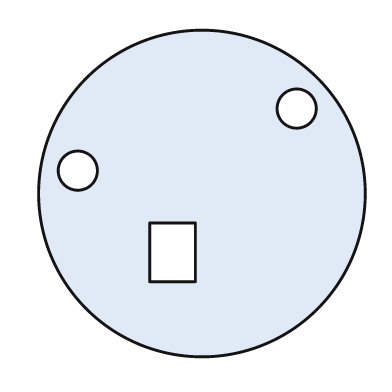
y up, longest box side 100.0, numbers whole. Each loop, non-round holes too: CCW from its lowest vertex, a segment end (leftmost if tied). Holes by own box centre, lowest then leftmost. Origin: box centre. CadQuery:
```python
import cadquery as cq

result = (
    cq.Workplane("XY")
    .moveTo(0.0, 0.0)
    .circle(50.0)
    .moveTo(-16.0, -27.0)
    .lineTo(-2.0, -27.0)
    .lineTo(-2.0, -9.0)
    .lineTo(-16.0, -9.0)
    .close()
    .moveTo(-38.0, 7.0)
    .circle(6.0)
    .moveTo(29.0, 26.0)
    .circle(6.0)
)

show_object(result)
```